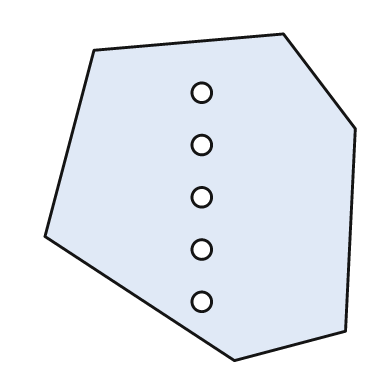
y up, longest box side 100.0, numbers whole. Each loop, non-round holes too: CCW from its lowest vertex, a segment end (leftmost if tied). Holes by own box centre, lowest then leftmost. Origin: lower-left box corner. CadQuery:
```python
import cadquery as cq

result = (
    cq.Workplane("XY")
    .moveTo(58.0, 0.0)
    .lineTo(92.0, 9.0)
    .lineTo(95.0, 71.0)
    .lineTo(73.0, 100.0)
    .lineTo(15.0, 95.0)
    .lineTo(0.0, 38.0)
    .close()
    .moveTo(48.0, 18.0)
    .circle(3.0)
    .moveTo(48.0, 34.0)
    .circle(3.0)
    .moveTo(48.0, 50.0)
    .circle(3.0)
    .moveTo(48.0, 66.0)
    .circle(3.0)
    .moveTo(48.0, 82.0)
    .circle(3.0)
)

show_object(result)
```